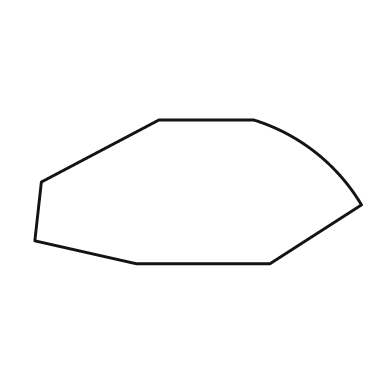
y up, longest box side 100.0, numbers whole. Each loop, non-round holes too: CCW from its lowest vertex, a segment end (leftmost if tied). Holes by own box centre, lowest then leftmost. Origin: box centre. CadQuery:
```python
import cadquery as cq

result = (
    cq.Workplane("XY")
    .moveTo(-19.0, -22.0)
    .lineTo(22.0, -22.0)
    .lineTo(50.0, -4.0)
    .threePointArc((36.0, 12.0), (17.0, 22.0))
    .lineTo(-12.0, 22.0)
    .lineTo(-48.0, 3.0)
    .lineTo(-50.0, -15.0)
    .close()
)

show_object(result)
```